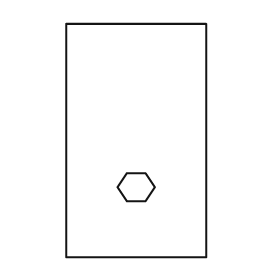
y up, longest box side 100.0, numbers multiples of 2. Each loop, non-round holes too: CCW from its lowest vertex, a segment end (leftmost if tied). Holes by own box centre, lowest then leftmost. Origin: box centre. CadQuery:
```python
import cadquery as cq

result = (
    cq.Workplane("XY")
    .moveTo(-30.0, -50.0)
    .lineTo(30.0, -50.0)
    .lineTo(30.0, 50.0)
    .lineTo(-30.0, 50.0)
    .close()
    .moveTo(-4.0, -26.0)
    .lineTo(4.0, -26.0)
    .lineTo(8.0, -20.0)
    .lineTo(4.0, -14.0)
    .lineTo(-4.0, -14.0)
    .lineTo(-8.0, -20.0)
    .close()
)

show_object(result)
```